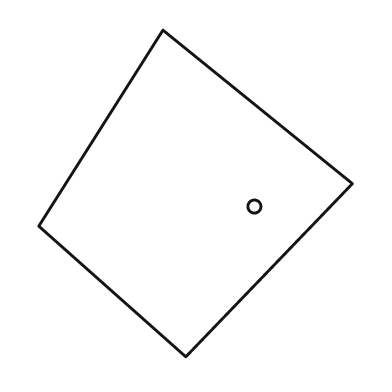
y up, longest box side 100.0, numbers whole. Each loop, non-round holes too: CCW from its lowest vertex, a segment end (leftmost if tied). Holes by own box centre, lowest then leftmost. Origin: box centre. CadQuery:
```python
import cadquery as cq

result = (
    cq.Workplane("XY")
    .moveTo(-3.0, -50.0)
    .lineTo(48.0, 3.0)
    .lineTo(-10.0, 50.0)
    .lineTo(-48.0, -10.0)
    .close()
    .moveTo(18.0, -4.0)
    .circle(2.0)
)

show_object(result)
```